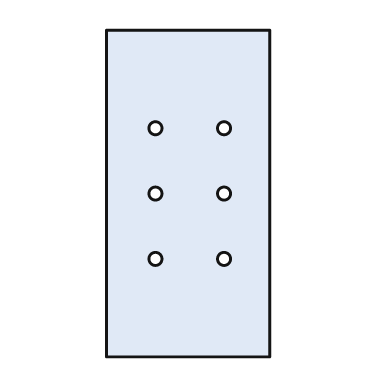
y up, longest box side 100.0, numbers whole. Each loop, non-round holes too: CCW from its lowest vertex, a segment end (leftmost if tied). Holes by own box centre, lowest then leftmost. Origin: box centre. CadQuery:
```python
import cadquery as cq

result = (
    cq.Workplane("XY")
    .moveTo(-25.0, -50.0)
    .lineTo(25.0, -50.0)
    .lineTo(25.0, 50.0)
    .lineTo(-25.0, 50.0)
    .close()
    .moveTo(-10.0, -20.0)
    .circle(2.0)
    .moveTo(11.0, -20.0)
    .circle(2.0)
    .moveTo(-10.0, 0.0)
    .circle(2.0)
    .moveTo(11.0, 0.0)
    .circle(2.0)
    .moveTo(-10.0, 20.0)
    .circle(2.0)
    .moveTo(11.0, 20.0)
    .circle(2.0)
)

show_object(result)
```